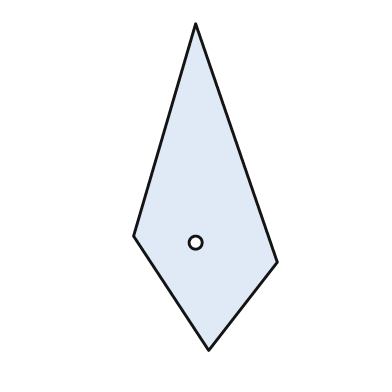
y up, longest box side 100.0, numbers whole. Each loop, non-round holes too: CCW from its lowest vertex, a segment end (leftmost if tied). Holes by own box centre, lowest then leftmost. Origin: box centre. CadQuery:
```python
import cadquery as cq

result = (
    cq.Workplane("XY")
    .moveTo(1.0, -50.0)
    .lineTo(22.0, -23.0)
    .lineTo(-3.0, 50.0)
    .lineTo(-22.0, -15.0)
    .close()
    .moveTo(-3.0, -17.0)
    .circle(2.0)
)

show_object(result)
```